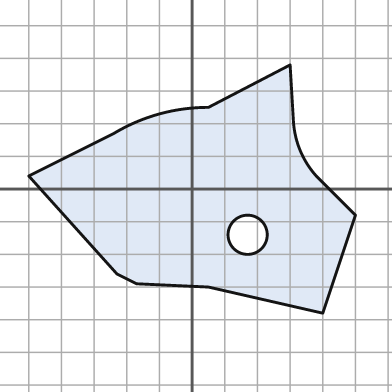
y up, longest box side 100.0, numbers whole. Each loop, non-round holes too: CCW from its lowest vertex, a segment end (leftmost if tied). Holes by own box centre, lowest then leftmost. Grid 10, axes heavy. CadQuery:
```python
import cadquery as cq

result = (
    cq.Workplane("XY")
    .moveTo(40.0, -38.0)
    .lineTo(50.0, -8.0)
    .lineTo(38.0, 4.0)
    .threePointArc((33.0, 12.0), (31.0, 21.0))
    .lineTo(30.0, 38.0)
    .lineTo(5.0, 25.0)
    .threePointArc((-10.0, 23.0), (-24.0, 17.0))
    .lineTo(-50.0, 4.0)
    .lineTo(-23.0, -26.0)
    .lineTo(-17.0, -29.0)
    .lineTo(5.0, -30.0)
    .close()
    .moveTo(17.0, -14.0)
    .circle(6.0)
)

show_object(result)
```